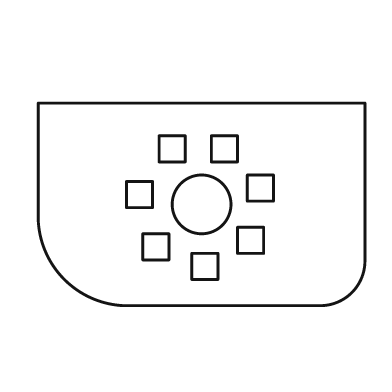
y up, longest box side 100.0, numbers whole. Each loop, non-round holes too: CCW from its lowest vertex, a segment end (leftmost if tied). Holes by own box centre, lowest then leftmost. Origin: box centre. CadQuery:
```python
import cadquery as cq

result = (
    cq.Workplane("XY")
    .moveTo(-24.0, -31.0)
    .lineTo(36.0, -31.0)
    .threePointArc((46.0, -27.0), (50.0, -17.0))
    .lineTo(50.0, 31.0)
    .lineTo(-50.0, 31.0)
    .lineTo(-50.0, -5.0)
    .threePointArc((-42.0, -23.0), (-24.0, -31.0))
    .close()
    .moveTo(-3.0, -23.0)
    .lineTo(5.0, -23.0)
    .lineTo(5.0, -15.0)
    .lineTo(-3.0, -15.0)
    .close()
    .moveTo(-18.0, -17.0)
    .lineTo(-10.0, -17.0)
    .lineTo(-10.0, -9.0)
    .lineTo(-18.0, -9.0)
    .close()
    .moveTo(11.0, -15.0)
    .lineTo(19.0, -15.0)
    .lineTo(19.0, -7.0)
    .lineTo(11.0, -7.0)
    .close()
    .moveTo(0.0, 0.0)
    .circle(9.0)
    .moveTo(-23.0, -1.0)
    .lineTo(-15.0, -1.0)
    .lineTo(-15.0, 7.0)
    .lineTo(-23.0, 7.0)
    .close()
    .moveTo(14.0, 1.0)
    .lineTo(22.0, 1.0)
    .lineTo(22.0, 9.0)
    .lineTo(14.0, 9.0)
    .close()
    .moveTo(-13.0, 13.0)
    .lineTo(-5.0, 13.0)
    .lineTo(-5.0, 21.0)
    .lineTo(-13.0, 21.0)
    .close()
    .moveTo(3.0, 13.0)
    .lineTo(11.0, 13.0)
    .lineTo(11.0, 21.0)
    .lineTo(3.0, 21.0)
    .close()
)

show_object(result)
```